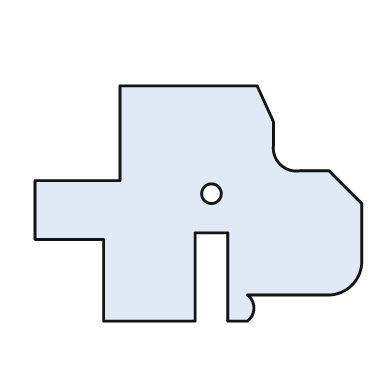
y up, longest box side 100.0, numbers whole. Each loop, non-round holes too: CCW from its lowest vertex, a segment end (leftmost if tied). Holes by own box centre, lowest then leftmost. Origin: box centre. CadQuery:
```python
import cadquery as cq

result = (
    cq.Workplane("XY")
    .moveTo(-29.0, -36.0)
    .lineTo(-1.0, -36.0)
    .lineTo(-1.0, -9.0)
    .lineTo(9.0, -9.0)
    .lineTo(9.0, -36.0)
    .lineTo(15.0, -36.0)
    .threePointArc((17.0, -32.0), (15.0, -28.0))
    .lineTo(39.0, -28.0)
    .threePointArc((47.0, -25.0), (50.0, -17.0))
    .lineTo(50.0, 0.0)
    .lineTo(40.0, 10.0)
    .lineTo(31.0, 10.0)
    .threePointArc((25.0, 12.0), (23.0, 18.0))
    .lineTo(23.0, 25.0)
    .lineTo(18.0, 36.0)
    .lineTo(-24.0, 36.0)
    .lineTo(-24.0, 7.0)
    .lineTo(-50.0, 7.0)
    .lineTo(-50.0, -11.0)
    .lineTo(-29.0, -11.0)
    .close()
    .moveTo(4.0, 3.0)
    .circle(3.0)
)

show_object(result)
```